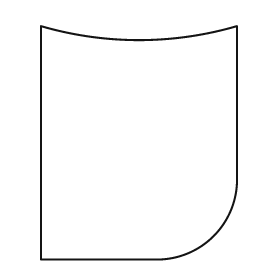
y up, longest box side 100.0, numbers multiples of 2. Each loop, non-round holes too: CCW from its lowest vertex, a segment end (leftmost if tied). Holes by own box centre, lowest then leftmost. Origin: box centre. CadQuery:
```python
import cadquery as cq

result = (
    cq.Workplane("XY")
    .moveTo(-42.0, -50.0)
    .lineTo(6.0, -50.0)
    .threePointArc((32.0, -40.0), (42.0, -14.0))
    .lineTo(42.0, 50.0)
    .threePointArc((0.0, 44.0), (-42.0, 50.0))
    .close()
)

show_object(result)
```